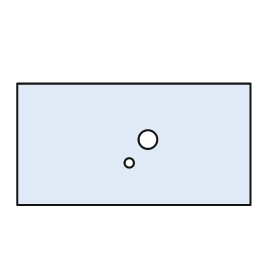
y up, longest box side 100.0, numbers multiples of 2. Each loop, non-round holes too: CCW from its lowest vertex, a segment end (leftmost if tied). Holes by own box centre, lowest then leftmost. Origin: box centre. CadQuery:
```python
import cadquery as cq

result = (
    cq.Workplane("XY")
    .moveTo(-50.0, -26.0)
    .lineTo(50.0, -26.0)
    .lineTo(50.0, 26.0)
    .lineTo(-50.0, 26.0)
    .close()
    .moveTo(-2.0, -8.0)
    .circle(2.0)
    .moveTo(6.0, 2.0)
    .circle(4.0)
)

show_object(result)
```